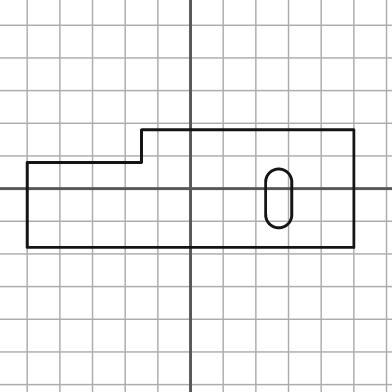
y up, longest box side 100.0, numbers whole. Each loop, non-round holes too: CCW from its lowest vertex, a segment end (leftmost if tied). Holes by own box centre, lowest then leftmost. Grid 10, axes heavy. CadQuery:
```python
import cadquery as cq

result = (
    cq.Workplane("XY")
    .moveTo(-50.0, -18.0)
    .lineTo(50.0, -18.0)
    .lineTo(50.0, 18.0)
    .lineTo(-15.0, 18.0)
    .lineTo(-15.0, 8.0)
    .lineTo(-50.0, 8.0)
    .close()
    .moveTo(23.0, -8.0)
    .threePointArc((27.0, -12.0), (31.0, -8.0))
    .lineTo(31.0, 2.0)
    .threePointArc((27.0, 6.0), (23.0, 2.0))
    .close()
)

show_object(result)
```